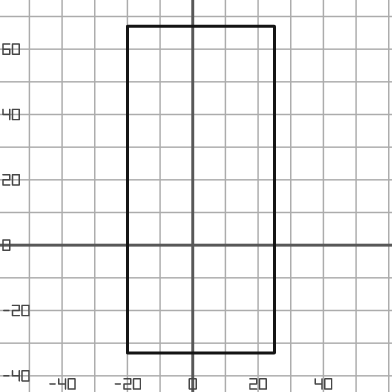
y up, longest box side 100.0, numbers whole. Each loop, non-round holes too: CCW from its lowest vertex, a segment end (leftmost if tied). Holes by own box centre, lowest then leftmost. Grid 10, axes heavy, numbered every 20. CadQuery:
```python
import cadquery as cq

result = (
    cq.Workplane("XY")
    .moveTo(-20.0, -33.0)
    .lineTo(25.0, -33.0)
    .lineTo(25.0, 67.0)
    .lineTo(-20.0, 67.0)
    .close()
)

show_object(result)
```